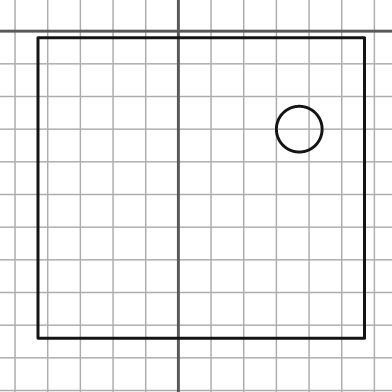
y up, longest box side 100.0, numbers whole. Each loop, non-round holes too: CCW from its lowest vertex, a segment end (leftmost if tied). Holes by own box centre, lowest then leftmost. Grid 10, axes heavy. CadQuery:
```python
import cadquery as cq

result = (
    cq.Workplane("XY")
    .moveTo(-43.0, -94.0)
    .lineTo(57.0, -94.0)
    .lineTo(57.0, -2.0)
    .lineTo(-43.0, -2.0)
    .close()
    .moveTo(37.0, -30.0)
    .circle(7.0)
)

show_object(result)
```